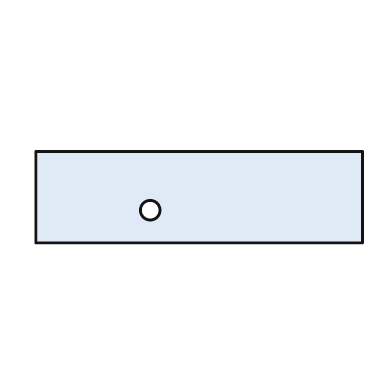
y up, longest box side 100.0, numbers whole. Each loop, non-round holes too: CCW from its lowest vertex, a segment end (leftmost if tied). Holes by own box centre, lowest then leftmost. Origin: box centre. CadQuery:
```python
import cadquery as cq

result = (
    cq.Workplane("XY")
    .moveTo(-50.0, -14.0)
    .lineTo(50.0, -14.0)
    .lineTo(50.0, 14.0)
    .lineTo(-50.0, 14.0)
    .close()
    .moveTo(-15.0, -4.0)
    .circle(3.0)
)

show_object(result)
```